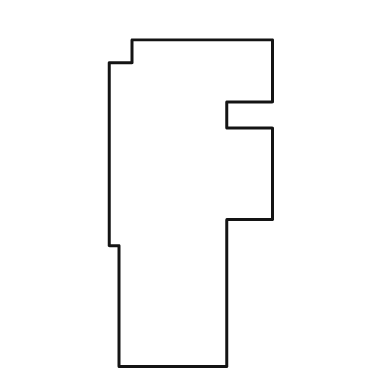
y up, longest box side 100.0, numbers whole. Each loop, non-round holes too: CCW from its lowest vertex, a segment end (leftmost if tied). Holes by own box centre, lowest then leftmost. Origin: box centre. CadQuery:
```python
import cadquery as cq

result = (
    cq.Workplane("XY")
    .moveTo(-22.0, -50.0)
    .lineTo(11.0, -50.0)
    .lineTo(11.0, -5.0)
    .lineTo(25.0, -5.0)
    .lineTo(25.0, 23.0)
    .lineTo(11.0, 23.0)
    .lineTo(11.0, 31.0)
    .lineTo(25.0, 31.0)
    .lineTo(25.0, 50.0)
    .lineTo(-18.0, 50.0)
    .lineTo(-18.0, 43.0)
    .lineTo(-25.0, 43.0)
    .lineTo(-25.0, -13.0)
    .lineTo(-22.0, -13.0)
    .close()
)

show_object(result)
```